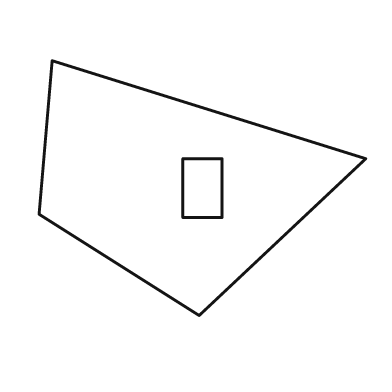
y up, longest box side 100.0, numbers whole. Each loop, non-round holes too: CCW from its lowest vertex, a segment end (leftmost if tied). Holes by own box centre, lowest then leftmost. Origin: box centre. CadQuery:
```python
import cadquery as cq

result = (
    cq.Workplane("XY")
    .moveTo(-1.0, -39.0)
    .lineTo(50.0, 9.0)
    .lineTo(-46.0, 39.0)
    .lineTo(-50.0, -8.0)
    .close()
    .moveTo(-6.0, -9.0)
    .lineTo(6.0, -9.0)
    .lineTo(6.0, 9.0)
    .lineTo(-6.0, 9.0)
    .close()
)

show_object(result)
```